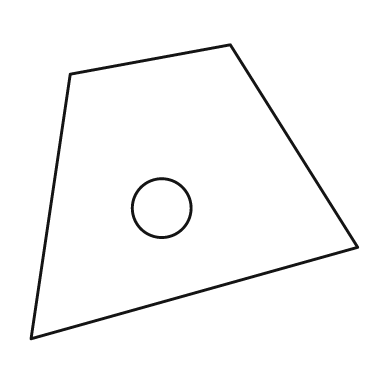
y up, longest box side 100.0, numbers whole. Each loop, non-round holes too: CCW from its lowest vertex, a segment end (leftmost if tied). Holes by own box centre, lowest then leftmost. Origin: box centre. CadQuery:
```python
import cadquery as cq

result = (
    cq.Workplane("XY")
    .moveTo(-50.0, -45.0)
    .lineTo(50.0, -17.0)
    .lineTo(11.0, 45.0)
    .lineTo(-38.0, 36.0)
    .close()
    .moveTo(-10.0, -5.0)
    .circle(9.0)
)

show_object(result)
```